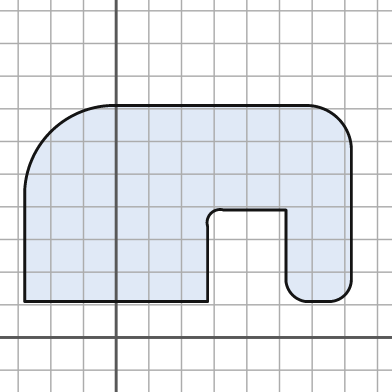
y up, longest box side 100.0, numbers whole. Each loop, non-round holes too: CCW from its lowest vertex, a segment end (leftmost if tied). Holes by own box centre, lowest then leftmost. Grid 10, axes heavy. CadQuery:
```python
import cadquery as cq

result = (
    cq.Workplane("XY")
    .moveTo(-28.0, 11.0)
    .lineTo(28.0, 11.0)
    .lineTo(28.0, 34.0)
    .threePointArc((29.0, 38.0), (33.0, 39.0))
    .lineTo(52.0, 39.0)
    .lineTo(52.0, 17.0)
    .threePointArc((54.0, 13.0), (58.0, 11.0))
    .lineTo(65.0, 11.0)
    .threePointArc((70.0, 13.0), (72.0, 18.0))
    .lineTo(72.0, 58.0)
    .threePointArc((68.0, 67.0), (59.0, 71.0))
    .lineTo(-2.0, 71.0)
    .threePointArc((-20.0, 63.0), (-28.0, 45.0))
    .close()
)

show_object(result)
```